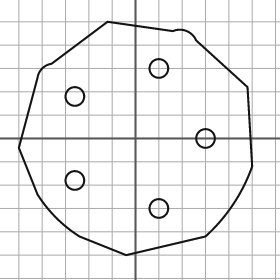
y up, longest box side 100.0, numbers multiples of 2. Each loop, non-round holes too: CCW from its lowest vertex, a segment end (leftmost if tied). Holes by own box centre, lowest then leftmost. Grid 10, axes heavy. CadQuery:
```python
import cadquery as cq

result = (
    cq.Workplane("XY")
    .moveTo(-4.0, -50.0)
    .lineTo(30.0, -42.0)
    .threePointArc((42.0, -28.0), (50.0, -12.0))
    .lineTo(48.0, 22.0)
    .lineTo(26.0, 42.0)
    .threePointArc((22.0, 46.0), (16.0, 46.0))
    .lineTo(-12.0, 50.0)
    .lineTo(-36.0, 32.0)
    .threePointArc((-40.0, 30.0), (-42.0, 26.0))
    .lineTo(-50.0, -4.0)
    .lineTo(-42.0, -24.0)
    .threePointArc((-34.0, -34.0), (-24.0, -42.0))
    .close()
    .moveTo(10.0, -30.0)
    .circle(4.0)
    .moveTo(-26.0, -18.0)
    .circle(4.0)
    .moveTo(30.0, 0.0)
    .circle(4.0)
    .moveTo(-26.0, 18.0)
    .circle(4.0)
    .moveTo(10.0, 30.0)
    .circle(4.0)
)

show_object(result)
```